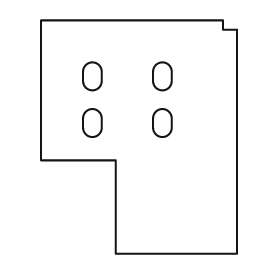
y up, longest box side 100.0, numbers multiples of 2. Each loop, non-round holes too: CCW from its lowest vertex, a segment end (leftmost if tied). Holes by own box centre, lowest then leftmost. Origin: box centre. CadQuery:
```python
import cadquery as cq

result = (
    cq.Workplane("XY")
    .moveTo(-10.0, -50.0)
    .lineTo(42.0, -50.0)
    .lineTo(42.0, 46.0)
    .lineTo(36.0, 46.0)
    .lineTo(36.0, 50.0)
    .lineTo(-42.0, 50.0)
    .lineTo(-42.0, -10.0)
    .lineTo(-10.0, -10.0)
    .close()
    .moveTo(-24.0, 4.0)
    .threePointArc((-20.0, 0.0), (-16.0, 4.0))
    .lineTo(-16.0, 8.0)
    .threePointArc((-20.0, 12.0), (-24.0, 8.0))
    .close()
    .moveTo(6.0, 4.0)
    .threePointArc((10.0, 0.0), (14.0, 4.0))
    .lineTo(14.0, 8.0)
    .threePointArc((10.0, 12.0), (6.0, 8.0))
    .close()
    .moveTo(-24.0, 24.0)
    .threePointArc((-20.0, 20.0), (-16.0, 24.0))
    .lineTo(-16.0, 28.0)
    .threePointArc((-20.0, 32.0), (-24.0, 28.0))
    .close()
    .moveTo(6.0, 24.0)
    .threePointArc((10.0, 20.0), (14.0, 24.0))
    .lineTo(14.0, 28.0)
    .threePointArc((10.0, 32.0), (6.0, 28.0))
    .close()
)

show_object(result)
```